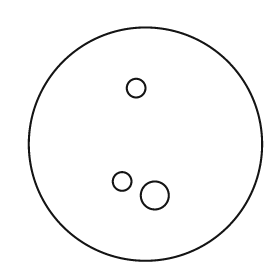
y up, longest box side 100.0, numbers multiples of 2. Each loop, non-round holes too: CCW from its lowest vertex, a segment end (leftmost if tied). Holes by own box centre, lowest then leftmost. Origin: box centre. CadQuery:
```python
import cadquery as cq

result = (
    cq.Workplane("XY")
    .moveTo(0.0, 0.0)
    .circle(50.0)
    .moveTo(4.0, -22.0)
    .circle(6.0)
    .moveTo(-10.0, -16.0)
    .circle(4.0)
    .moveTo(-4.0, 24.0)
    .circle(4.0)
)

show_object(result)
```